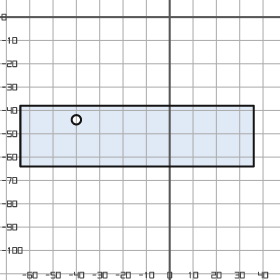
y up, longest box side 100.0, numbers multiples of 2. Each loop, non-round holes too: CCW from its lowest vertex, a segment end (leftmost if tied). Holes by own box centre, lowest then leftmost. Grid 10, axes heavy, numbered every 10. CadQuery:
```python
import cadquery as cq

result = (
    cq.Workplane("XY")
    .moveTo(-64.0, -64.0)
    .lineTo(36.0, -64.0)
    .lineTo(36.0, -38.0)
    .lineTo(-64.0, -38.0)
    .close()
    .moveTo(-40.0, -44.0)
    .circle(2.0)
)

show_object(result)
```